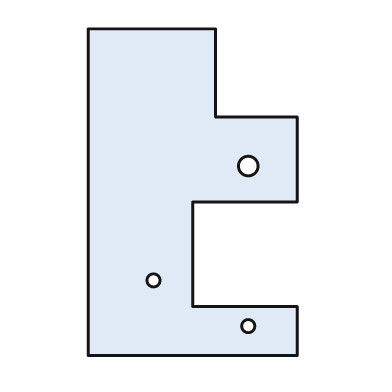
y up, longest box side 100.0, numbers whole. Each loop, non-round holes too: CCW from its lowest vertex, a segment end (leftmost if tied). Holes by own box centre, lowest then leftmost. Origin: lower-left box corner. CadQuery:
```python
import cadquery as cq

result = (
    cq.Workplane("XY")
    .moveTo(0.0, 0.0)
    .lineTo(64.0, 0.0)
    .lineTo(64.0, 15.0)
    .lineTo(32.0, 15.0)
    .lineTo(32.0, 47.0)
    .lineTo(64.0, 47.0)
    .lineTo(64.0, 73.0)
    .lineTo(39.0, 73.0)
    .lineTo(39.0, 100.0)
    .lineTo(0.0, 100.0)
    .close()
    .moveTo(49.0, 9.0)
    .circle(2.0)
    .moveTo(20.0, 23.0)
    .circle(2.0)
    .moveTo(49.0, 58.0)
    .circle(3.0)
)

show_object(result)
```